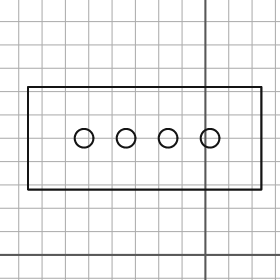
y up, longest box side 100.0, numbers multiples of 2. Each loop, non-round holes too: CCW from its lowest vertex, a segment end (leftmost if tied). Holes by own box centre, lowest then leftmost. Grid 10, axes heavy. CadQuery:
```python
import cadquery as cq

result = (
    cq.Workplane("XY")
    .moveTo(-76.0, 28.0)
    .lineTo(24.0, 28.0)
    .lineTo(24.0, 72.0)
    .lineTo(-76.0, 72.0)
    .close()
    .moveTo(-52.0, 50.0)
    .circle(4.0)
    .moveTo(-34.0, 50.0)
    .circle(4.0)
    .moveTo(-16.0, 50.0)
    .circle(4.0)
    .moveTo(2.0, 50.0)
    .circle(4.0)
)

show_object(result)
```